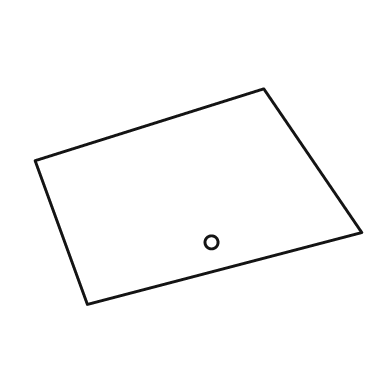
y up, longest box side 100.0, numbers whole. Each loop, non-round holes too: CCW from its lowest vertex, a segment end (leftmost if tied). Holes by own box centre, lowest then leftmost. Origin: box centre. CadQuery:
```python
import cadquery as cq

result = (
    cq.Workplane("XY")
    .moveTo(-34.0, -33.0)
    .lineTo(50.0, -11.0)
    .lineTo(20.0, 33.0)
    .lineTo(-50.0, 11.0)
    .close()
    .moveTo(4.0, -14.0)
    .circle(2.0)
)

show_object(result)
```